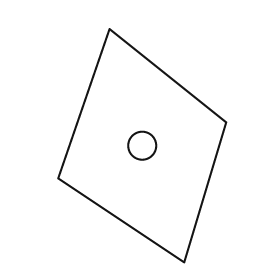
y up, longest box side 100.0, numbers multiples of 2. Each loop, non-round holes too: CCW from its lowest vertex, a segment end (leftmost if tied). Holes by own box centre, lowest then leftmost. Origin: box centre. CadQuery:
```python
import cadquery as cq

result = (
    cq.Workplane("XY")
    .moveTo(18.0, -50.0)
    .lineTo(36.0, 10.0)
    .lineTo(-14.0, 50.0)
    .lineTo(-36.0, -14.0)
    .close()
    .moveTo(0.0, 0.0)
    .circle(6.0)
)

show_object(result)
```